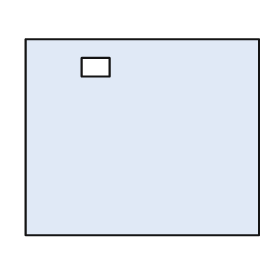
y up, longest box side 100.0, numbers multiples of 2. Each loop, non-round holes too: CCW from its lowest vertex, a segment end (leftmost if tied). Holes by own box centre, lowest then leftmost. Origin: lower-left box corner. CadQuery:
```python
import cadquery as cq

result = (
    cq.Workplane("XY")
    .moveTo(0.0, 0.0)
    .lineTo(100.0, 0.0)
    .lineTo(100.0, 84.0)
    .lineTo(0.0, 84.0)
    .close()
    .moveTo(24.0, 68.0)
    .lineTo(36.0, 68.0)
    .lineTo(36.0, 76.0)
    .lineTo(24.0, 76.0)
    .close()
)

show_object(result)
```